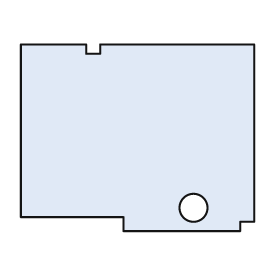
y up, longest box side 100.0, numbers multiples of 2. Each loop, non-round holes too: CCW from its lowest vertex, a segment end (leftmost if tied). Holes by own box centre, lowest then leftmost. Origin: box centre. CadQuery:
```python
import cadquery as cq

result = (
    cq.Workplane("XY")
    .moveTo(-6.0, -40.0)
    .lineTo(44.0, -40.0)
    .lineTo(44.0, -36.0)
    .lineTo(50.0, -36.0)
    .lineTo(50.0, 40.0)
    .lineTo(-16.0, 40.0)
    .lineTo(-16.0, 36.0)
    .lineTo(-22.0, 36.0)
    .lineTo(-22.0, 40.0)
    .lineTo(-50.0, 40.0)
    .lineTo(-50.0, -34.0)
    .lineTo(-6.0, -34.0)
    .close()
    .moveTo(24.0, -30.0)
    .circle(6.0)
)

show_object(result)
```